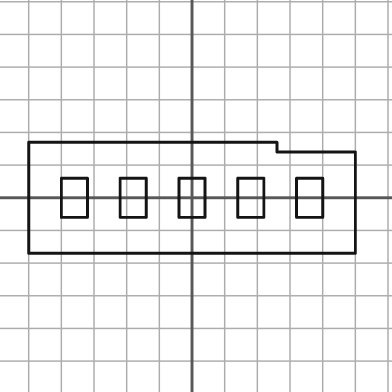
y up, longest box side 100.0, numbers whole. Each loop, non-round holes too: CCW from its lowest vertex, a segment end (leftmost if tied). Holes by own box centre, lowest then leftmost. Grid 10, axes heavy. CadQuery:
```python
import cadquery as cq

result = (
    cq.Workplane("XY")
    .moveTo(-50.0, -17.0)
    .lineTo(50.0, -17.0)
    .lineTo(50.0, 14.0)
    .lineTo(26.0, 14.0)
    .lineTo(26.0, 17.0)
    .lineTo(-50.0, 17.0)
    .close()
    .moveTo(-40.0, -6.0)
    .lineTo(-32.0, -6.0)
    .lineTo(-32.0, 6.0)
    .lineTo(-40.0, 6.0)
    .close()
    .moveTo(-22.0, -6.0)
    .lineTo(-14.0, -6.0)
    .lineTo(-14.0, 6.0)
    .lineTo(-22.0, 6.0)
    .close()
    .moveTo(-4.0, -6.0)
    .lineTo(4.0, -6.0)
    .lineTo(4.0, 6.0)
    .lineTo(-4.0, 6.0)
    .close()
    .moveTo(14.0, -6.0)
    .lineTo(22.0, -6.0)
    .lineTo(22.0, 6.0)
    .lineTo(14.0, 6.0)
    .close()
    .moveTo(32.0, -6.0)
    .lineTo(40.0, -6.0)
    .lineTo(40.0, 6.0)
    .lineTo(32.0, 6.0)
    .close()
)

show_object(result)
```